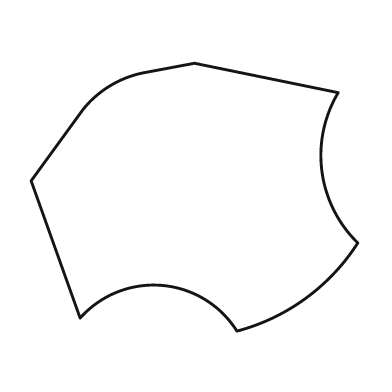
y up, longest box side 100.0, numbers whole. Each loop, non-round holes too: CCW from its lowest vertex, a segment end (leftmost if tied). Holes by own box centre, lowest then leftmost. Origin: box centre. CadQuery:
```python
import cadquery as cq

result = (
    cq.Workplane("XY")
    .moveTo(13.0, -41.0)
    .threePointArc((34.0, -31.0), (50.0, -14.0))
    .threePointArc((39.0, 8.0), (44.0, 32.0))
    .lineTo(0.0, 41.0)
    .lineTo(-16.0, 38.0)
    .threePointArc((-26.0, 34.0), (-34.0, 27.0))
    .lineTo(-50.0, 5.0)
    .lineTo(-35.0, -37.0)
    .threePointArc((-10.0, -27.0), (13.0, -41.0))
    .close()
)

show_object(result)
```